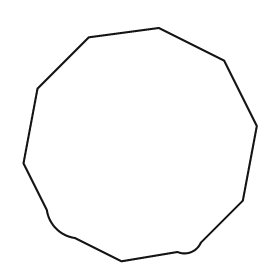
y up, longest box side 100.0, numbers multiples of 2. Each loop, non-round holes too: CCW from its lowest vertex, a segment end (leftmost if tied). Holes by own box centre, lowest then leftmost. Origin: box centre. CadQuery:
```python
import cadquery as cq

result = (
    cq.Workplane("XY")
    .moveTo(-8.0, -50.0)
    .lineTo(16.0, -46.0)
    .threePointArc((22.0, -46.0), (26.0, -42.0))
    .lineTo(44.0, -24.0)
    .lineTo(50.0, 8.0)
    .lineTo(36.0, 36.0)
    .lineTo(8.0, 50.0)
    .lineTo(-22.0, 46.0)
    .lineTo(-44.0, 24.0)
    .lineTo(-50.0, -8.0)
    .lineTo(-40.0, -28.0)
    .threePointArc((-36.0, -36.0), (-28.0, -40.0))
    .close()
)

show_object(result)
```